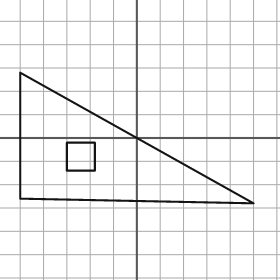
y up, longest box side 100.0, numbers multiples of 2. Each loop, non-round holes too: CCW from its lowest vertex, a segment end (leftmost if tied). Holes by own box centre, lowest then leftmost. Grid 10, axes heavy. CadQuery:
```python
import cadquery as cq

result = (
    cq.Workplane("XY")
    .moveTo(50.0, -28.0)
    .lineTo(-50.0, 28.0)
    .lineTo(-50.0, -26.0)
    .close()
    .moveTo(-30.0, -14.0)
    .lineTo(-18.0, -14.0)
    .lineTo(-18.0, -2.0)
    .lineTo(-30.0, -2.0)
    .close()
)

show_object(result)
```